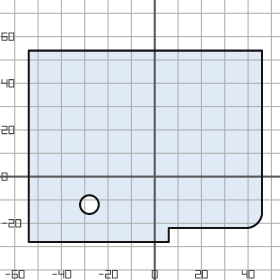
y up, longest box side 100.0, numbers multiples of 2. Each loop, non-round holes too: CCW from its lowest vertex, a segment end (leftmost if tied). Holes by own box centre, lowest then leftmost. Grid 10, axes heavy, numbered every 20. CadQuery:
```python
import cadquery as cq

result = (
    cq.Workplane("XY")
    .moveTo(-54.0, -28.0)
    .lineTo(6.0, -28.0)
    .lineTo(6.0, -22.0)
    .lineTo(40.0, -22.0)
    .threePointArc((44.0, -20.0), (46.0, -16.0))
    .lineTo(46.0, 54.0)
    .lineTo(-54.0, 54.0)
    .close()
    .moveTo(-28.0, -12.0)
    .circle(4.0)
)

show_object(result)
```